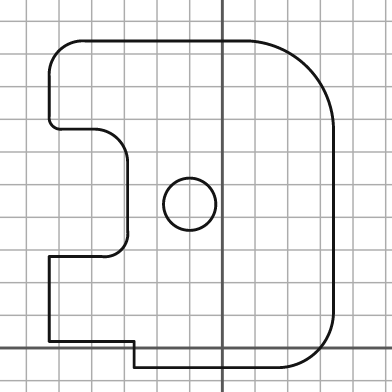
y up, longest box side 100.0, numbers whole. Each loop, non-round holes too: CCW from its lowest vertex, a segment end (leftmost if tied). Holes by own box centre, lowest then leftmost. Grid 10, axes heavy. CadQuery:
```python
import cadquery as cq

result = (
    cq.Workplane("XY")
    .moveTo(-27.0, -6.0)
    .lineTo(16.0, -6.0)
    .threePointArc((29.0, -1.0), (34.0, 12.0))
    .lineTo(34.0, 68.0)
    .threePointArc((26.0, 86.0), (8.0, 94.0))
    .lineTo(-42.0, 94.0)
    .threePointArc((-50.0, 91.0), (-53.0, 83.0))
    .lineTo(-53.0, 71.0)
    .threePointArc((-52.0, 68.0), (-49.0, 67.0))
    .lineTo(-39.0, 67.0)
    .threePointArc((-32.0, 64.0), (-29.0, 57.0))
    .lineTo(-29.0, 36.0)
    .threePointArc((-31.0, 30.0), (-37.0, 28.0))
    .lineTo(-53.0, 28.0)
    .lineTo(-53.0, 2.0)
    .lineTo(-27.0, 2.0)
    .close()
    .moveTo(-10.0, 44.0)
    .circle(8.0)
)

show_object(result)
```